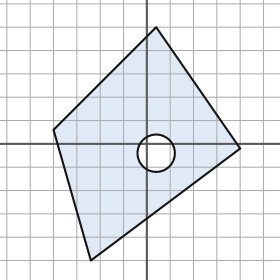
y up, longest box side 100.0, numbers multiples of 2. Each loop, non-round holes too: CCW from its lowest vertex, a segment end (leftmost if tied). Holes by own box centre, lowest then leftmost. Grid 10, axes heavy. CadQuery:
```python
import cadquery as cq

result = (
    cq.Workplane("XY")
    .moveTo(-24.0, -50.0)
    .lineTo(40.0, -2.0)
    .lineTo(4.0, 50.0)
    .lineTo(-40.0, 6.0)
    .close()
    .moveTo(4.0, -4.0)
    .circle(8.0)
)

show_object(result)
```